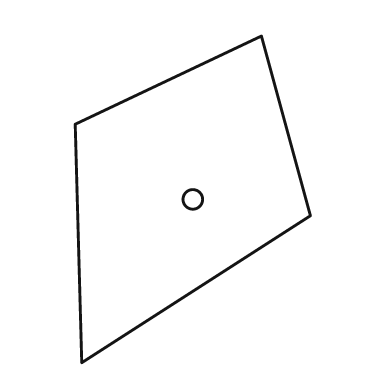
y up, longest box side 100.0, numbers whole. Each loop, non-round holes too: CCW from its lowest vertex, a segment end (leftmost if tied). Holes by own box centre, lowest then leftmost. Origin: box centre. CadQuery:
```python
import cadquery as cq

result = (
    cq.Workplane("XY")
    .moveTo(-34.0, -50.0)
    .lineTo(36.0, -5.0)
    .lineTo(21.0, 50.0)
    .lineTo(-36.0, 23.0)
    .close()
    .moveTo(0.0, 0.0)
    .circle(3.0)
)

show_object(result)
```